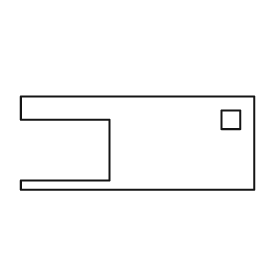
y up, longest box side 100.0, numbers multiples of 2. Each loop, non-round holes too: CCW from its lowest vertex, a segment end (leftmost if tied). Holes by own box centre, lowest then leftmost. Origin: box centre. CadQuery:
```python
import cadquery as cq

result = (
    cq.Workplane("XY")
    .moveTo(-50.0, -20.0)
    .lineTo(50.0, -20.0)
    .lineTo(50.0, 20.0)
    .lineTo(-50.0, 20.0)
    .lineTo(-50.0, 10.0)
    .lineTo(-12.0, 10.0)
    .lineTo(-12.0, -16.0)
    .lineTo(-50.0, -16.0)
    .close()
    .moveTo(36.0, 6.0)
    .lineTo(44.0, 6.0)
    .lineTo(44.0, 14.0)
    .lineTo(36.0, 14.0)
    .close()
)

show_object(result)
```